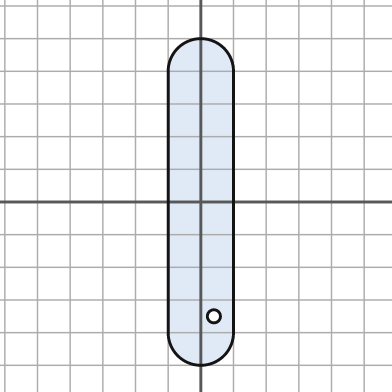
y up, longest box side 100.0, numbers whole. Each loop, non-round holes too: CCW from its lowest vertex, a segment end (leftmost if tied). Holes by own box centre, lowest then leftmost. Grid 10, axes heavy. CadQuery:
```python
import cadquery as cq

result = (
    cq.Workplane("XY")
    .moveTo(-10.0, -40.0)
    .threePointArc((0.0, -50.0), (10.0, -40.0))
    .lineTo(10.0, 40.0)
    .threePointArc((0.0, 50.0), (-10.0, 40.0))
    .close()
    .moveTo(4.0, -35.0)
    .circle(2.0)
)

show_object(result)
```